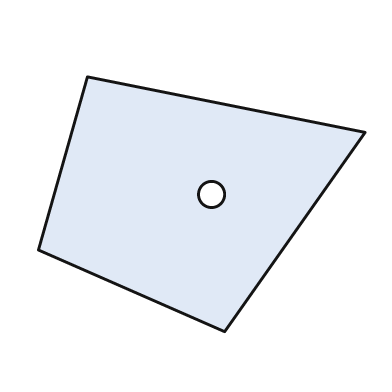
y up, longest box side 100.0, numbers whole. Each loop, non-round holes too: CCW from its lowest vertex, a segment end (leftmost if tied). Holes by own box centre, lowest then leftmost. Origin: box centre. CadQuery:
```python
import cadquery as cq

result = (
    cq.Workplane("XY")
    .moveTo(7.0, -39.0)
    .lineTo(50.0, 22.0)
    .lineTo(-35.0, 39.0)
    .lineTo(-50.0, -14.0)
    .close()
    .moveTo(3.0, 3.0)
    .circle(4.0)
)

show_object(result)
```